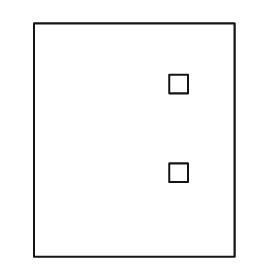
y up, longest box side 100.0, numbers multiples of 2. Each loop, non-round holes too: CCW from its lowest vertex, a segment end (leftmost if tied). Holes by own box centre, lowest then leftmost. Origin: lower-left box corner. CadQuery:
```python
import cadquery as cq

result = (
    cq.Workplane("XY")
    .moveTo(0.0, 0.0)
    .lineTo(86.0, 0.0)
    .lineTo(86.0, 100.0)
    .lineTo(0.0, 100.0)
    .close()
    .moveTo(58.0, 32.0)
    .lineTo(66.0, 32.0)
    .lineTo(66.0, 40.0)
    .lineTo(58.0, 40.0)
    .close()
    .moveTo(58.0, 70.0)
    .lineTo(66.0, 70.0)
    .lineTo(66.0, 78.0)
    .lineTo(58.0, 78.0)
    .close()
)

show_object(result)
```